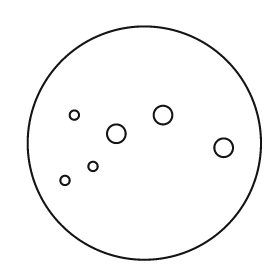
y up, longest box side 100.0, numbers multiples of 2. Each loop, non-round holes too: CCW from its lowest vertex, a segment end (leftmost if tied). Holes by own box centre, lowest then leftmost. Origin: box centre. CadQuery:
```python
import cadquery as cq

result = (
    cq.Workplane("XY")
    .moveTo(0.0, 0.0)
    .circle(50.0)
    .moveTo(-34.0, -16.0)
    .circle(2.0)
    .moveTo(-22.0, -10.0)
    .circle(2.0)
    .moveTo(34.0, -2.0)
    .circle(4.0)
    .moveTo(-12.0, 4.0)
    .circle(4.0)
    .moveTo(-30.0, 12.0)
    .circle(2.0)
    .moveTo(8.0, 12.0)
    .circle(4.0)
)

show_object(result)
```